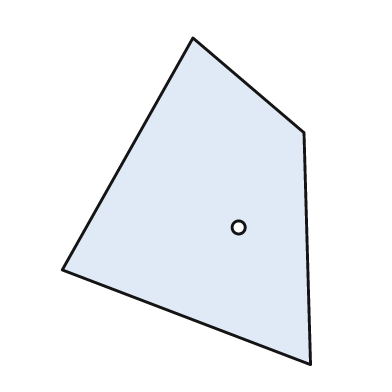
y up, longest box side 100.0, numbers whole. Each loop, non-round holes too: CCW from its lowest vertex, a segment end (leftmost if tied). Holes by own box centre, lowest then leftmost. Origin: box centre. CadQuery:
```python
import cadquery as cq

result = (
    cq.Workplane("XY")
    .moveTo(38.0, -50.0)
    .lineTo(36.0, 21.0)
    .lineTo(2.0, 50.0)
    .lineTo(-38.0, -21.0)
    .close()
    .moveTo(16.0, -8.0)
    .circle(2.0)
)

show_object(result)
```